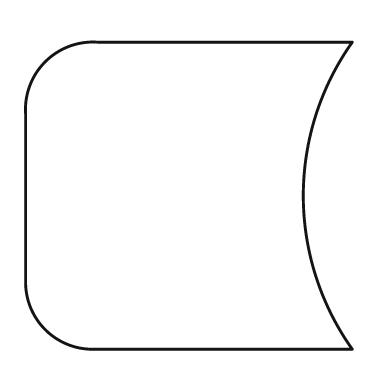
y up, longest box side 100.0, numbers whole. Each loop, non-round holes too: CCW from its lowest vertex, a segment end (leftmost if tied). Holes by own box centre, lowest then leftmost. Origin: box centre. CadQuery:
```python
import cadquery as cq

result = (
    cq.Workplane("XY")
    .moveTo(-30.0, -47.0)
    .lineTo(50.0, -47.0)
    .threePointArc((35.0, 0.0), (50.0, 47.0))
    .lineTo(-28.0, 47.0)
    .threePointArc((-44.0, 41.0), (-50.0, 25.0))
    .lineTo(-50.0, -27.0)
    .threePointArc((-44.0, -41.0), (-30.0, -47.0))
    .close()
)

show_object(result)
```